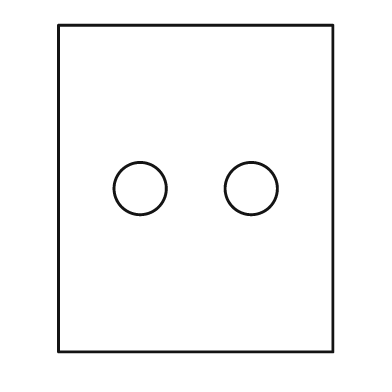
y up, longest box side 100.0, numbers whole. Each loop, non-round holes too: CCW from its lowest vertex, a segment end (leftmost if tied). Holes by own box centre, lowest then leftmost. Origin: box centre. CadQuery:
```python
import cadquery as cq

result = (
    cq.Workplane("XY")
    .moveTo(-42.0, -50.0)
    .lineTo(42.0, -50.0)
    .lineTo(42.0, 50.0)
    .lineTo(-42.0, 50.0)
    .close()
    .moveTo(-17.0, 0.0)
    .circle(8.0)
    .moveTo(17.0, 0.0)
    .circle(8.0)
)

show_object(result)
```